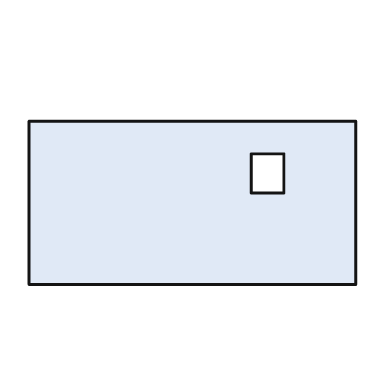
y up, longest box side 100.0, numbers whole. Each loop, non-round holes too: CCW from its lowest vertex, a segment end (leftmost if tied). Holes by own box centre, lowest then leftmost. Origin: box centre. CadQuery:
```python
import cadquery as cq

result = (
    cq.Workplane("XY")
    .moveTo(-50.0, -25.0)
    .lineTo(50.0, -25.0)
    .lineTo(50.0, 25.0)
    .lineTo(-50.0, 25.0)
    .close()
    .moveTo(18.0, 3.0)
    .lineTo(28.0, 3.0)
    .lineTo(28.0, 15.0)
    .lineTo(18.0, 15.0)
    .close()
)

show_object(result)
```